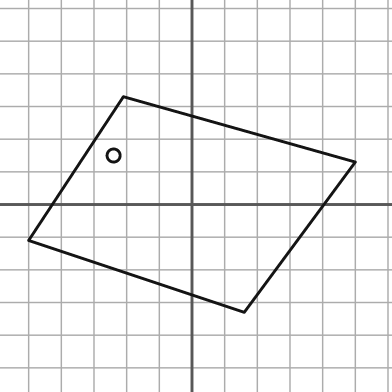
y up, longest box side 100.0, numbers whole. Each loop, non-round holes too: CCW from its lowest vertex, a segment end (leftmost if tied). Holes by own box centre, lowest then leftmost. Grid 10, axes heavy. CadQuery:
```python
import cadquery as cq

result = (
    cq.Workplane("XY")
    .moveTo(16.0, -33.0)
    .lineTo(50.0, 13.0)
    .lineTo(-21.0, 33.0)
    .lineTo(-50.0, -11.0)
    .close()
    .moveTo(-24.0, 15.0)
    .circle(2.0)
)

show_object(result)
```